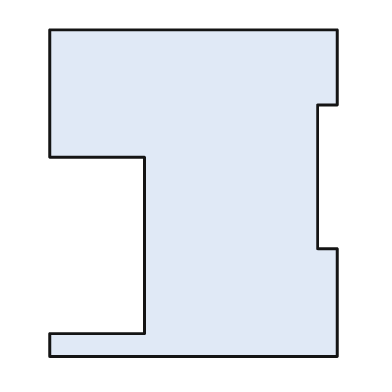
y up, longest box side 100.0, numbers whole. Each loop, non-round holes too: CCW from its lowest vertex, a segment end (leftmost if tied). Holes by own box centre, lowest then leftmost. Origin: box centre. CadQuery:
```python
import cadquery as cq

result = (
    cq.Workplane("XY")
    .moveTo(-44.0, -50.0)
    .lineTo(44.0, -50.0)
    .lineTo(44.0, -17.0)
    .lineTo(38.0, -17.0)
    .lineTo(38.0, 27.0)
    .lineTo(44.0, 27.0)
    .lineTo(44.0, 50.0)
    .lineTo(-44.0, 50.0)
    .lineTo(-44.0, 11.0)
    .lineTo(-15.0, 11.0)
    .lineTo(-15.0, -43.0)
    .lineTo(-44.0, -43.0)
    .close()
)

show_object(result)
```